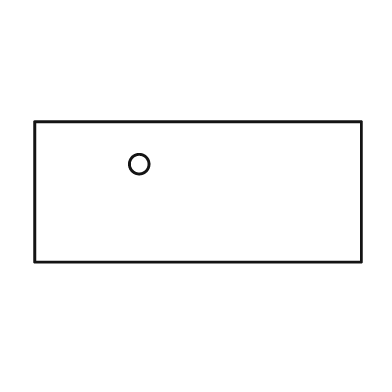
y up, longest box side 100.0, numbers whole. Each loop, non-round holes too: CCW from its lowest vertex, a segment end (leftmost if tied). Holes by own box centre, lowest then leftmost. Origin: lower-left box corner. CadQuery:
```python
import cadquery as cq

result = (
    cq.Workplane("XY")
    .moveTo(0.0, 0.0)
    .lineTo(100.0, 0.0)
    .lineTo(100.0, 43.0)
    .lineTo(0.0, 43.0)
    .close()
    .moveTo(32.0, 30.0)
    .circle(3.0)
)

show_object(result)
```